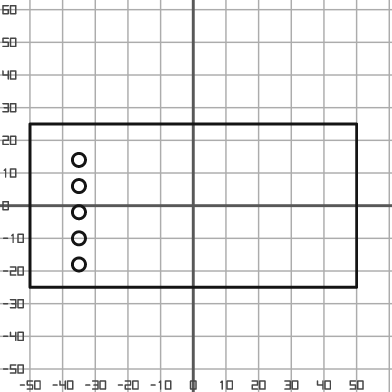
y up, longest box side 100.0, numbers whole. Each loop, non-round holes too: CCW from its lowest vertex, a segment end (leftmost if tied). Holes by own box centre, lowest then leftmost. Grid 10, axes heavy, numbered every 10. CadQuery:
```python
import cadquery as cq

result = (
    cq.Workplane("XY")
    .moveTo(-50.0, -25.0)
    .lineTo(50.0, -25.0)
    .lineTo(50.0, 25.0)
    .lineTo(-50.0, 25.0)
    .close()
    .moveTo(-35.0, -18.0)
    .circle(2.0)
    .moveTo(-35.0, -10.0)
    .circle(2.0)
    .moveTo(-35.0, -2.0)
    .circle(2.0)
    .moveTo(-35.0, 6.0)
    .circle(2.0)
    .moveTo(-35.0, 14.0)
    .circle(2.0)
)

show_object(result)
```